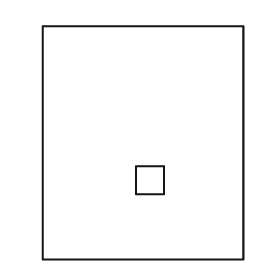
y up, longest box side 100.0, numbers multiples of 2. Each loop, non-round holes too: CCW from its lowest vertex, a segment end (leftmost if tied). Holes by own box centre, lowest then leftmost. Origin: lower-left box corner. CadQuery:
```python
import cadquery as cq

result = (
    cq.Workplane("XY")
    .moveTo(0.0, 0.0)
    .lineTo(86.0, 0.0)
    .lineTo(86.0, 100.0)
    .lineTo(0.0, 100.0)
    .close()
    .moveTo(40.0, 28.0)
    .lineTo(52.0, 28.0)
    .lineTo(52.0, 40.0)
    .lineTo(40.0, 40.0)
    .close()
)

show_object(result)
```